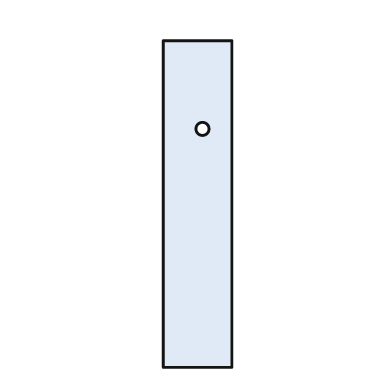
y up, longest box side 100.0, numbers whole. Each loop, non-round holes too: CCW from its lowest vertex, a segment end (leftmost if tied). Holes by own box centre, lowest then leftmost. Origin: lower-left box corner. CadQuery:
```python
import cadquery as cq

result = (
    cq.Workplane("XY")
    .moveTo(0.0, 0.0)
    .lineTo(21.0, 0.0)
    .lineTo(21.0, 100.0)
    .lineTo(0.0, 100.0)
    .close()
    .moveTo(12.0, 73.0)
    .circle(2.0)
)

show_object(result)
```